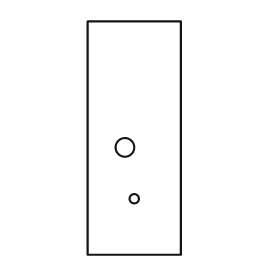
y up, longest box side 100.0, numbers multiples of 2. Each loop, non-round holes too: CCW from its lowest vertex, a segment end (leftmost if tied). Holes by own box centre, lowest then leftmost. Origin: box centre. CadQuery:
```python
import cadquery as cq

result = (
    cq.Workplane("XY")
    .moveTo(-20.0, -50.0)
    .lineTo(20.0, -50.0)
    .lineTo(20.0, 50.0)
    .lineTo(-20.0, 50.0)
    .close()
    .moveTo(0.0, -26.0)
    .circle(2.0)
    .moveTo(-4.0, -4.0)
    .circle(4.0)
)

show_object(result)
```